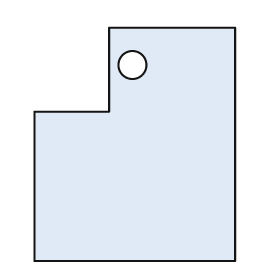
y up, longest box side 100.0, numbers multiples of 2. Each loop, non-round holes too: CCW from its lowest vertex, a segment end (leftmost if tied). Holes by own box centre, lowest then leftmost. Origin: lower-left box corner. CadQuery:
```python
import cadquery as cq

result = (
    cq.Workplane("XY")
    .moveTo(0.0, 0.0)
    .lineTo(86.0, 0.0)
    .lineTo(86.0, 100.0)
    .lineTo(32.0, 100.0)
    .lineTo(32.0, 64.0)
    .lineTo(0.0, 64.0)
    .close()
    .moveTo(42.0, 84.0)
    .circle(6.0)
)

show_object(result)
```